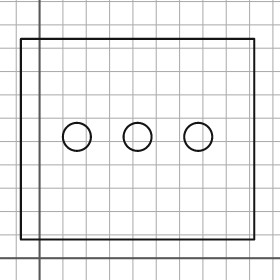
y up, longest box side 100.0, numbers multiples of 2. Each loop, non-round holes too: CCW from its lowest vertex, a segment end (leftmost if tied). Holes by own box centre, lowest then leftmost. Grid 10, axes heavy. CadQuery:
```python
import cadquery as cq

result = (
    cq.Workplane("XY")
    .moveTo(-8.0, 8.0)
    .lineTo(92.0, 8.0)
    .lineTo(92.0, 94.0)
    .lineTo(-8.0, 94.0)
    .close()
    .moveTo(16.0, 52.0)
    .circle(6.0)
    .moveTo(42.0, 52.0)
    .circle(6.0)
    .moveTo(68.0, 52.0)
    .circle(6.0)
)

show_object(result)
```